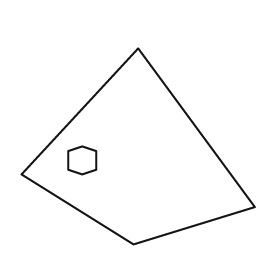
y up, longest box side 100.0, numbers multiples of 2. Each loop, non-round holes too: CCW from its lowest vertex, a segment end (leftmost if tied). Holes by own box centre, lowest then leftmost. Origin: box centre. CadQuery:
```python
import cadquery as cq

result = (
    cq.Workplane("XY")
    .moveTo(-2.0, -42.0)
    .lineTo(50.0, -26.0)
    .lineTo(0.0, 42.0)
    .lineTo(-50.0, -12.0)
    .close()
    .moveTo(-24.0, -12.0)
    .lineTo(-18.0, -10.0)
    .lineTo(-18.0, -2.0)
    .lineTo(-24.0, 0.0)
    .lineTo(-30.0, -2.0)
    .lineTo(-30.0, -10.0)
    .close()
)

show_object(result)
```